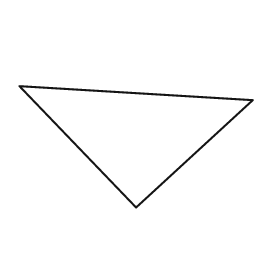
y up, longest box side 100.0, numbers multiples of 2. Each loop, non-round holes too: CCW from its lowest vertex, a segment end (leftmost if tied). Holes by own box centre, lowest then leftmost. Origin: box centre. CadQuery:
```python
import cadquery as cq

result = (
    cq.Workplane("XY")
    .moveTo(0.0, -26.0)
    .lineTo(50.0, 20.0)
    .lineTo(-50.0, 26.0)
    .close()
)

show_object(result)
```